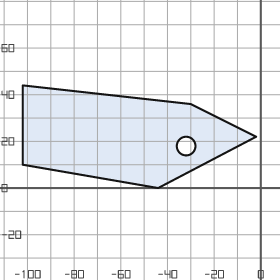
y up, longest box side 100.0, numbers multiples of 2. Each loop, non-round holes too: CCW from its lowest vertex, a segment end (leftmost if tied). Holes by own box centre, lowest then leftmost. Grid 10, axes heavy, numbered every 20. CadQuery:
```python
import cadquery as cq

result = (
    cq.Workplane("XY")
    .moveTo(-44.0, 0.0)
    .lineTo(-2.0, 22.0)
    .lineTo(-30.0, 36.0)
    .lineTo(-102.0, 44.0)
    .lineTo(-102.0, 10.0)
    .close()
    .moveTo(-32.0, 18.0)
    .circle(4.0)
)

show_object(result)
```